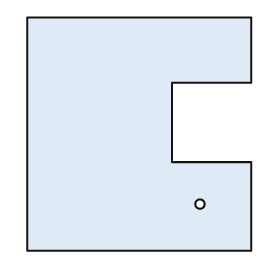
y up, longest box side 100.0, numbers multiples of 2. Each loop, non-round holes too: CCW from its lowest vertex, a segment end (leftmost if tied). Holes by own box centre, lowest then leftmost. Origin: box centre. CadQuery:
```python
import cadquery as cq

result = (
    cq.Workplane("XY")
    .moveTo(-48.0, -50.0)
    .lineTo(48.0, -50.0)
    .lineTo(48.0, -12.0)
    .lineTo(14.0, -12.0)
    .lineTo(14.0, 22.0)
    .lineTo(48.0, 22.0)
    .lineTo(48.0, 50.0)
    .lineTo(-48.0, 50.0)
    .close()
    .moveTo(26.0, -30.0)
    .circle(2.0)
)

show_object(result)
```